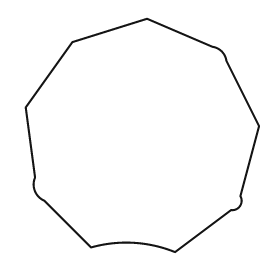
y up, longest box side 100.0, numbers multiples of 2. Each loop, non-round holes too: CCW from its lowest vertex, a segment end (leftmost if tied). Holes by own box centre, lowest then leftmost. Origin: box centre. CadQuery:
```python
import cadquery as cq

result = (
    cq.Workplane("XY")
    .moveTo(14.0, -50.0)
    .lineTo(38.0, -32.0)
    .threePointArc((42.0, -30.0), (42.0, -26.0))
    .lineTo(50.0, 4.0)
    .lineTo(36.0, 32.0)
    .threePointArc((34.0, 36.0), (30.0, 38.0))
    .lineTo(2.0, 50.0)
    .lineTo(-30.0, 40.0)
    .lineTo(-50.0, 12.0)
    .lineTo(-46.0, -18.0)
    .threePointArc((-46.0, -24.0), (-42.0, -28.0))
    .lineTo(-22.0, -48.0)
    .threePointArc((-4.0, -46.0), (14.0, -50.0))
    .close()
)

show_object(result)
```